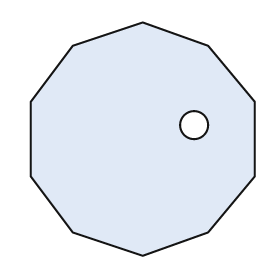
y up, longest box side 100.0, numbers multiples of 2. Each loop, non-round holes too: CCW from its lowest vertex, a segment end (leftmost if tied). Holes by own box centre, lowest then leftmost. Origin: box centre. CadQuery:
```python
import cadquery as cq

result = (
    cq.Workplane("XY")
    .moveTo(0.0, -50.0)
    .lineTo(28.0, -40.0)
    .lineTo(48.0, -16.0)
    .lineTo(48.0, 16.0)
    .lineTo(28.0, 40.0)
    .lineTo(0.0, 50.0)
    .lineTo(-30.0, 40.0)
    .lineTo(-48.0, 16.0)
    .lineTo(-48.0, -16.0)
    .lineTo(-30.0, -40.0)
    .close()
    .moveTo(22.0, 6.0)
    .circle(6.0)
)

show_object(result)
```